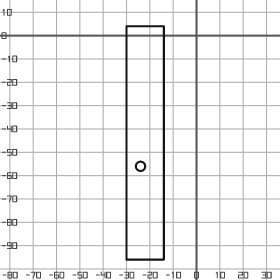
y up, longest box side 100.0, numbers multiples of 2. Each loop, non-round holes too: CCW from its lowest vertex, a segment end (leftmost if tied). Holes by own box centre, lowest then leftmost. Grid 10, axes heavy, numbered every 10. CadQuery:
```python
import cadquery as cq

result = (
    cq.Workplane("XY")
    .moveTo(-30.0, -96.0)
    .lineTo(-14.0, -96.0)
    .lineTo(-14.0, 4.0)
    .lineTo(-30.0, 4.0)
    .close()
    .moveTo(-24.0, -56.0)
    .circle(2.0)
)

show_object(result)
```